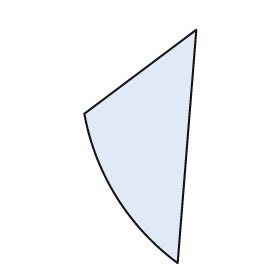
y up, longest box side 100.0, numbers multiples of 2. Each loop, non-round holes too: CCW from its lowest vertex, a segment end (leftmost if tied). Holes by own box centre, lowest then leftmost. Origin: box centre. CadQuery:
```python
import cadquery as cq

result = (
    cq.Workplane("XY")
    .moveTo(16.0, -50.0)
    .lineTo(24.0, 50.0)
    .lineTo(-24.0, 14.0)
    .threePointArc((-10.0, -22.0), (16.0, -50.0))
    .close()
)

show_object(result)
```